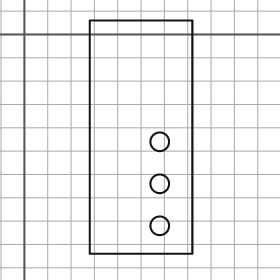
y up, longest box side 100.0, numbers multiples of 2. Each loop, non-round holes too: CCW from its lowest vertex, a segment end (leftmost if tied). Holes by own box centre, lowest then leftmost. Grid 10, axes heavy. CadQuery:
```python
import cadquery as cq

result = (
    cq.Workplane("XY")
    .moveTo(28.0, -94.0)
    .lineTo(72.0, -94.0)
    .lineTo(72.0, 6.0)
    .lineTo(28.0, 6.0)
    .close()
    .moveTo(58.0, -82.0)
    .circle(4.0)
    .moveTo(58.0, -64.0)
    .circle(4.0)
    .moveTo(58.0, -46.0)
    .circle(4.0)
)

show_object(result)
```